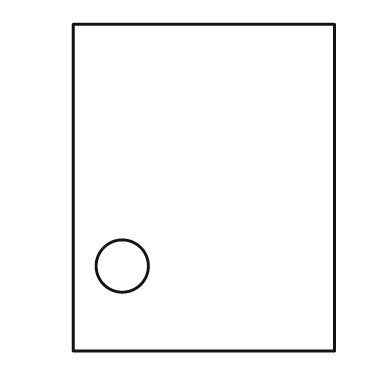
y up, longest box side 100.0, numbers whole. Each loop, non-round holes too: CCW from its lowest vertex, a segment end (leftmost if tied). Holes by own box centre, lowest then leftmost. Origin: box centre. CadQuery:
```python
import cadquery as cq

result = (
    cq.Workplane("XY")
    .moveTo(-40.0, -50.0)
    .lineTo(40.0, -50.0)
    .lineTo(40.0, 50.0)
    .lineTo(-40.0, 50.0)
    .close()
    .moveTo(-25.0, -24.0)
    .circle(8.0)
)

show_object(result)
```